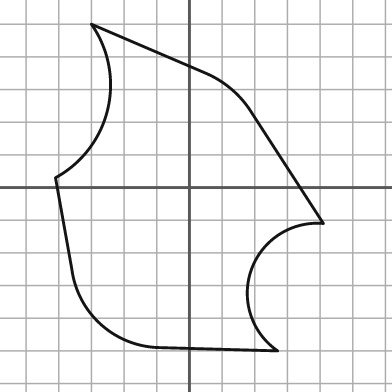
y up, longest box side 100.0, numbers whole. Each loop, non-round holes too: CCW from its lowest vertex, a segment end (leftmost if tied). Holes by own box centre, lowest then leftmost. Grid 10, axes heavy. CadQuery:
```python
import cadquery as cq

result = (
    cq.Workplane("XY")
    .moveTo(27.0, -50.0)
    .threePointArc((19.0, -25.0), (41.0, -11.0))
    .lineTo(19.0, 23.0)
    .threePointArc((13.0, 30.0), (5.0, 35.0))
    .lineTo(-30.0, 50.0)
    .threePointArc((-25.0, 24.0), (-41.0, 3.0))
    .lineTo(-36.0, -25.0)
    .threePointArc((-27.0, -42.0), (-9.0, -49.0))
    .close()
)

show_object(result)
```